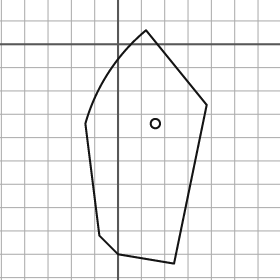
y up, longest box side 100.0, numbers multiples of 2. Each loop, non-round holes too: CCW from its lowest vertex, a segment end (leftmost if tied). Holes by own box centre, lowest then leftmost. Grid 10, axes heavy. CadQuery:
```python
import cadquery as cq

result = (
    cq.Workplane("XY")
    .moveTo(24.0, -94.0)
    .lineTo(38.0, -26.0)
    .lineTo(12.0, 6.0)
    .threePointArc((-4.0, -12.0), (-14.0, -34.0))
    .lineTo(-8.0, -82.0)
    .lineTo(0.0, -90.0)
    .close()
    .moveTo(16.0, -34.0)
    .circle(2.0)
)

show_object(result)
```